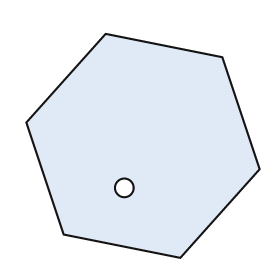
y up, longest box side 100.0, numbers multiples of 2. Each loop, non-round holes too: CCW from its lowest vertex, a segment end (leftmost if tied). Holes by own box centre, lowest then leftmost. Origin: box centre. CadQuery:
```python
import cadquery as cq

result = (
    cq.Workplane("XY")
    .moveTo(16.0, -48.0)
    .lineTo(50.0, -10.0)
    .lineTo(34.0, 38.0)
    .lineTo(-16.0, 48.0)
    .lineTo(-50.0, 10.0)
    .lineTo(-34.0, -38.0)
    .close()
    .moveTo(-8.0, -18.0)
    .circle(4.0)
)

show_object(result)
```